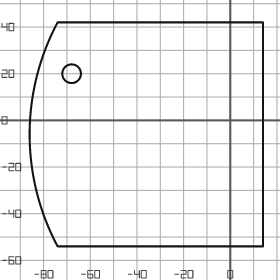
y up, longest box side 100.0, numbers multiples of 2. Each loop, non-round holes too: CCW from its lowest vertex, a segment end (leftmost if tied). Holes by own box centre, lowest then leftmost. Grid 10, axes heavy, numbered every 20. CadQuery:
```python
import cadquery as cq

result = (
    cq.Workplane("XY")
    .moveTo(-74.0, -54.0)
    .lineTo(14.0, -54.0)
    .lineTo(14.0, 42.0)
    .lineTo(-74.0, 42.0)
    .threePointArc((-86.0, -6.0), (-74.0, -54.0))
    .close()
    .moveTo(-68.0, 20.0)
    .circle(4.0)
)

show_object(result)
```